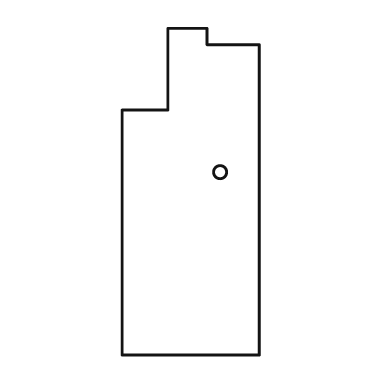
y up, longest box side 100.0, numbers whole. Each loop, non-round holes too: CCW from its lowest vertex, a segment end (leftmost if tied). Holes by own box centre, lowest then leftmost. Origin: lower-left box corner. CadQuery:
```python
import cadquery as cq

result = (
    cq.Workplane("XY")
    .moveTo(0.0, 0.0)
    .lineTo(42.0, 0.0)
    .lineTo(42.0, 95.0)
    .lineTo(26.0, 95.0)
    .lineTo(26.0, 100.0)
    .lineTo(14.0, 100.0)
    .lineTo(14.0, 75.0)
    .lineTo(0.0, 75.0)
    .close()
    .moveTo(30.0, 56.0)
    .circle(2.0)
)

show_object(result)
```